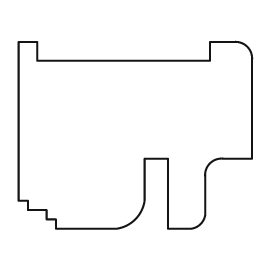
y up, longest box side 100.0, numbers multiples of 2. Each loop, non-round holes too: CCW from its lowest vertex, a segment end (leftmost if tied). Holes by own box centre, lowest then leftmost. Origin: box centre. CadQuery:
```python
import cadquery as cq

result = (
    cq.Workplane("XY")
    .moveTo(-34.0, -40.0)
    .lineTo(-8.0, -40.0)
    .threePointArc((0.0, -36.0), (4.0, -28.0))
    .lineTo(4.0, -10.0)
    .lineTo(14.0, -10.0)
    .lineTo(14.0, -40.0)
    .lineTo(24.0, -40.0)
    .threePointArc((28.0, -38.0), (30.0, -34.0))
    .lineTo(30.0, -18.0)
    .threePointArc((32.0, -12.0), (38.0, -10.0))
    .lineTo(50.0, -10.0)
    .lineTo(50.0, 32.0)
    .threePointArc((48.0, 38.0), (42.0, 40.0))
    .lineTo(32.0, 40.0)
    .lineTo(32.0, 32.0)
    .lineTo(-42.0, 32.0)
    .lineTo(-42.0, 40.0)
    .lineTo(-50.0, 40.0)
    .lineTo(-50.0, -28.0)
    .lineTo(-46.0, -28.0)
    .lineTo(-46.0, -32.0)
    .lineTo(-38.0, -32.0)
    .lineTo(-38.0, -36.0)
    .lineTo(-34.0, -36.0)
    .close()
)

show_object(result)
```